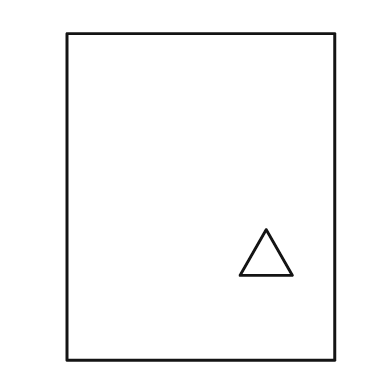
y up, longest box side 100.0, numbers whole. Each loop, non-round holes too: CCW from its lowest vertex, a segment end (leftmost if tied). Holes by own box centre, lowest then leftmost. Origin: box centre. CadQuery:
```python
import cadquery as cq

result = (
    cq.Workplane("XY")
    .moveTo(-41.0, -50.0)
    .lineTo(41.0, -50.0)
    .lineTo(41.0, 50.0)
    .lineTo(-41.0, 50.0)
    .close()
    .moveTo(12.0, -24.0)
    .lineTo(28.0, -24.0)
    .lineTo(20.0, -10.0)
    .close()
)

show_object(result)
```